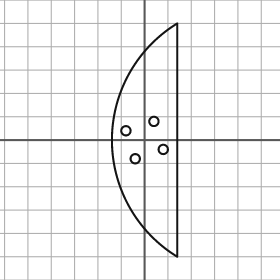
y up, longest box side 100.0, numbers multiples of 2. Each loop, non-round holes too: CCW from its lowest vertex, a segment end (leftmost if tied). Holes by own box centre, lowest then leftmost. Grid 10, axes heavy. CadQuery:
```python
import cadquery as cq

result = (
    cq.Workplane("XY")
    .moveTo(14.0, -50.0)
    .lineTo(14.0, 50.0)
    .threePointArc((-14.0, 0.0), (14.0, -50.0))
    .close()
    .moveTo(-4.0, -8.0)
    .circle(2.0)
    .moveTo(8.0, -4.0)
    .circle(2.0)
    .moveTo(-8.0, 4.0)
    .circle(2.0)
    .moveTo(4.0, 8.0)
    .circle(2.0)
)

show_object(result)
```